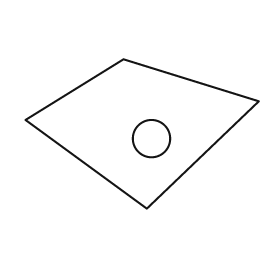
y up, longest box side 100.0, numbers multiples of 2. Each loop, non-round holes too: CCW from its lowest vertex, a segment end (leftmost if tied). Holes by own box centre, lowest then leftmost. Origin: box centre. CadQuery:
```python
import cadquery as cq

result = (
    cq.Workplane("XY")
    .moveTo(2.0, -32.0)
    .lineTo(50.0, 14.0)
    .lineTo(-8.0, 32.0)
    .lineTo(-50.0, 6.0)
    .close()
    .moveTo(4.0, -2.0)
    .circle(8.0)
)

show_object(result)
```